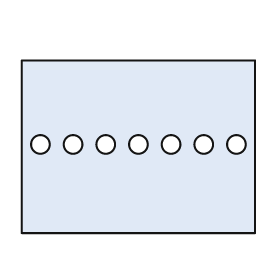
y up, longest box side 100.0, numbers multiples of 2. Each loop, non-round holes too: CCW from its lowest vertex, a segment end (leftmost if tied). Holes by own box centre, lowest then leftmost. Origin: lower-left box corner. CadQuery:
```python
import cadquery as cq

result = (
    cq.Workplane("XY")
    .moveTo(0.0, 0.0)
    .lineTo(100.0, 0.0)
    .lineTo(100.0, 74.0)
    .lineTo(0.0, 74.0)
    .close()
    .moveTo(8.0, 38.0)
    .circle(4.0)
    .moveTo(22.0, 38.0)
    .circle(4.0)
    .moveTo(36.0, 38.0)
    .circle(4.0)
    .moveTo(50.0, 38.0)
    .circle(4.0)
    .moveTo(64.0, 38.0)
    .circle(4.0)
    .moveTo(78.0, 38.0)
    .circle(4.0)
    .moveTo(92.0, 38.0)
    .circle(4.0)
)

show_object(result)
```